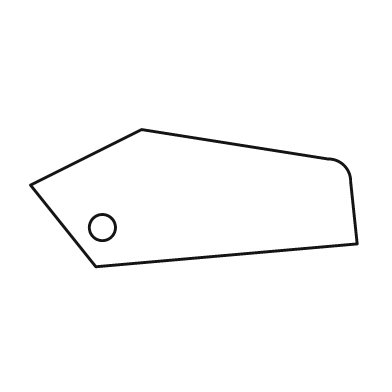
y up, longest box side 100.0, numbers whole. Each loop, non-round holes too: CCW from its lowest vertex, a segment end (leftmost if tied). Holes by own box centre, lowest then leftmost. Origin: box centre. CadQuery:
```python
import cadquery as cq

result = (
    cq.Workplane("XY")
    .moveTo(-30.0, -21.0)
    .lineTo(50.0, -14.0)
    .lineTo(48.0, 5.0)
    .threePointArc((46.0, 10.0), (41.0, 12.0))
    .lineTo(-16.0, 21.0)
    .lineTo(-50.0, 4.0)
    .close()
    .moveTo(-28.0, -9.0)
    .circle(4.0)
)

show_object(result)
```